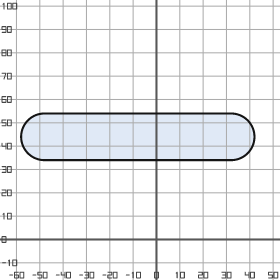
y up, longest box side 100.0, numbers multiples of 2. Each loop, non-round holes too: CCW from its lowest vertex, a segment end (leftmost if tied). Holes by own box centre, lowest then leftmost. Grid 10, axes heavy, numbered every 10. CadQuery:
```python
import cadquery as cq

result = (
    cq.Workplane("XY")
    .moveTo(-48.0, 34.0)
    .lineTo(32.0, 34.0)
    .threePointArc((42.0, 44.0), (32.0, 54.0))
    .lineTo(-48.0, 54.0)
    .threePointArc((-58.0, 44.0), (-48.0, 34.0))
    .close()
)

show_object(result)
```